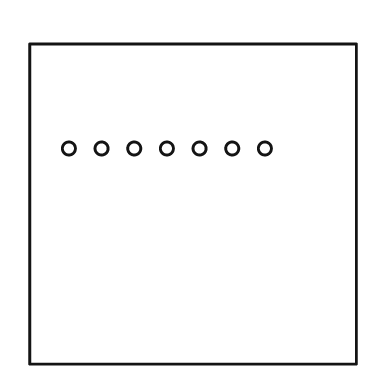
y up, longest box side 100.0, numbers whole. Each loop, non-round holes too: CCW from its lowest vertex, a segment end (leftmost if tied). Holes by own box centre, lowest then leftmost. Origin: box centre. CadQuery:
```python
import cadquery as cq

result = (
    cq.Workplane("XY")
    .moveTo(-50.0, -49.0)
    .lineTo(50.0, -49.0)
    .lineTo(50.0, 49.0)
    .lineTo(-50.0, 49.0)
    .close()
    .moveTo(-38.0, 17.0)
    .circle(2.0)
    .moveTo(-28.0, 17.0)
    .circle(2.0)
    .moveTo(-18.0, 17.0)
    .circle(2.0)
    .moveTo(-8.0, 17.0)
    .circle(2.0)
    .moveTo(2.0, 17.0)
    .circle(2.0)
    .moveTo(12.0, 17.0)
    .circle(2.0)
    .moveTo(22.0, 17.0)
    .circle(2.0)
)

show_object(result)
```